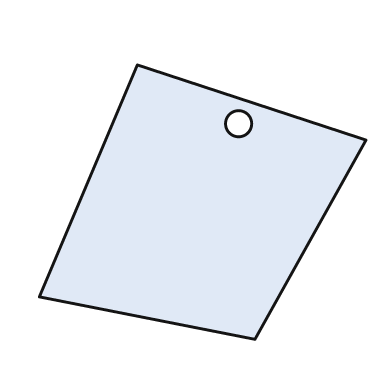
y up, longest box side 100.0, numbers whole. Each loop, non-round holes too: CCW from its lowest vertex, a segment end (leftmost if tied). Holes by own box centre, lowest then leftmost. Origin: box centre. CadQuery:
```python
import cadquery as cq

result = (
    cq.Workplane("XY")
    .moveTo(16.0, -42.0)
    .lineTo(50.0, 19.0)
    .lineTo(-20.0, 42.0)
    .lineTo(-50.0, -29.0)
    .close()
    .moveTo(11.0, 24.0)
    .circle(4.0)
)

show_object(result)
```